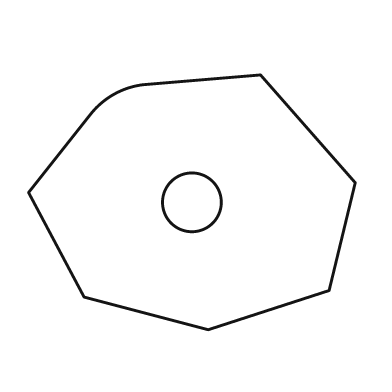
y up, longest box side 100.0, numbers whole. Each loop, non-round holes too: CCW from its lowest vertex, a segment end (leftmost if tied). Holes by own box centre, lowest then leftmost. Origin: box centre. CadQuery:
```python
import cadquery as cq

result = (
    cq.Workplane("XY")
    .moveTo(5.0, -39.0)
    .lineTo(42.0, -27.0)
    .lineTo(50.0, 6.0)
    .lineTo(21.0, 39.0)
    .lineTo(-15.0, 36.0)
    .threePointArc((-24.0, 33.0), (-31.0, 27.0))
    .lineTo(-50.0, 3.0)
    .lineTo(-33.0, -29.0)
    .close()
    .moveTo(0.0, 0.0)
    .circle(9.0)
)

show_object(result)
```